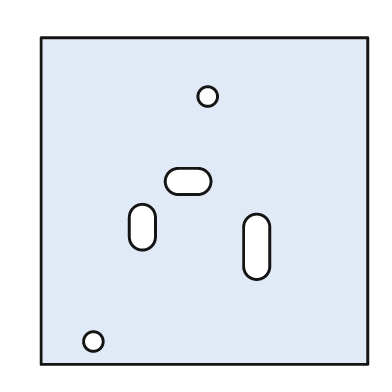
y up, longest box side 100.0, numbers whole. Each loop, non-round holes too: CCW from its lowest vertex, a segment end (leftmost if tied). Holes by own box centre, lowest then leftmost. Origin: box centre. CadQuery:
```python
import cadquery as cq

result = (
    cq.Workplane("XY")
    .moveTo(-50.0, -50.0)
    .lineTo(50.0, -50.0)
    .lineTo(50.0, 50.0)
    .lineTo(-50.0, 50.0)
    .close()
    .moveTo(-34.0, -43.0)
    .circle(3.0)
    .moveTo(12.0, -20.0)
    .threePointArc((16.0, -24.0), (20.0, -20.0))
    .lineTo(20.0, -8.0)
    .threePointArc((16.0, -4.0), (12.0, -8.0))
    .close()
    .moveTo(-23.0, -11.0)
    .threePointArc((-19.0, -15.0), (-15.0, -11.0))
    .lineTo(-15.0, -5.0)
    .threePointArc((-19.0, -1.0), (-23.0, -5.0))
    .close()
    .moveTo(-8.0, 2.0)
    .lineTo(-2.0, 2.0)
    .threePointArc((2.0, 6.0), (-2.0, 10.0))
    .lineTo(-8.0, 10.0)
    .threePointArc((-12.0, 6.0), (-8.0, 2.0))
    .close()
    .moveTo(1.0, 32.0)
    .circle(3.0)
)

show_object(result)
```